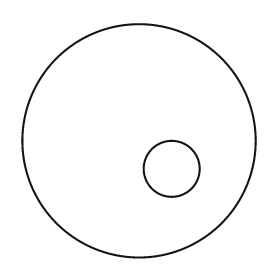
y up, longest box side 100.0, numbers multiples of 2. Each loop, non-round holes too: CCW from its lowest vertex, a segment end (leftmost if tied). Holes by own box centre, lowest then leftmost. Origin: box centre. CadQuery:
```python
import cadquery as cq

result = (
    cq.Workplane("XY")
    .moveTo(0.0, 0.0)
    .circle(50.0)
    .moveTo(14.0, -12.0)
    .circle(12.0)
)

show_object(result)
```